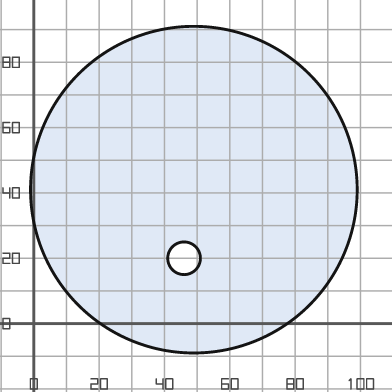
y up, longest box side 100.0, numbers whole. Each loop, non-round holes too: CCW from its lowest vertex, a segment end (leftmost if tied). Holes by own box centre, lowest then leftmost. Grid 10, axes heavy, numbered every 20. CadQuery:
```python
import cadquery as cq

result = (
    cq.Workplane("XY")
    .moveTo(49.0, 41.0)
    .circle(50.0)
    .moveTo(46.0, 20.0)
    .circle(5.0)
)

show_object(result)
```